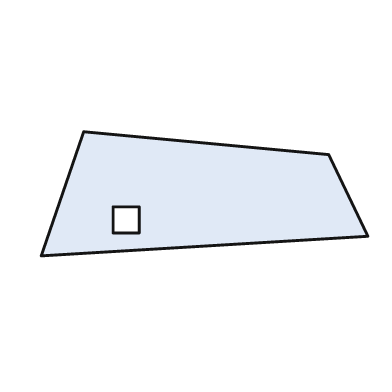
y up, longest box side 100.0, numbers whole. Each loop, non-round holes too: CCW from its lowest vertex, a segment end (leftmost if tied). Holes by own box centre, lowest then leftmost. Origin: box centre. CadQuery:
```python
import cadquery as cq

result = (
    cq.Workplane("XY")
    .moveTo(-50.0, -19.0)
    .lineTo(50.0, -13.0)
    .lineTo(38.0, 12.0)
    .lineTo(-37.0, 19.0)
    .close()
    .moveTo(-28.0, -12.0)
    .lineTo(-20.0, -12.0)
    .lineTo(-20.0, -4.0)
    .lineTo(-28.0, -4.0)
    .close()
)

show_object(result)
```